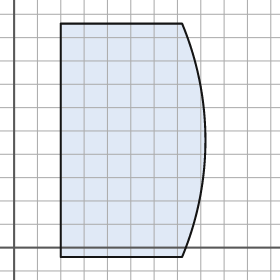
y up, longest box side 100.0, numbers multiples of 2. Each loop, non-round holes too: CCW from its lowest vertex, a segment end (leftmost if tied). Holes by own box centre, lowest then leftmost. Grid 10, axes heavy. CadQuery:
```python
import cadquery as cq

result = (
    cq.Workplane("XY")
    .moveTo(20.0, -4.0)
    .lineTo(72.0, -4.0)
    .threePointArc((82.0, 46.0), (72.0, 96.0))
    .lineTo(20.0, 96.0)
    .close()
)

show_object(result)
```